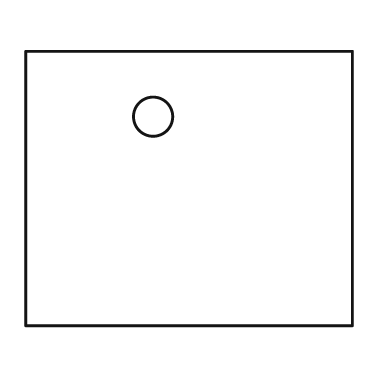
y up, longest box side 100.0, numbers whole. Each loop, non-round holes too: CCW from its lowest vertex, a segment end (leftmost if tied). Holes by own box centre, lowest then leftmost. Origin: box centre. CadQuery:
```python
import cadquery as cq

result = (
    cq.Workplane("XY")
    .moveTo(-50.0, -42.0)
    .lineTo(50.0, -42.0)
    .lineTo(50.0, 42.0)
    .lineTo(-50.0, 42.0)
    .close()
    .moveTo(-11.0, 22.0)
    .circle(6.0)
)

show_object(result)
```